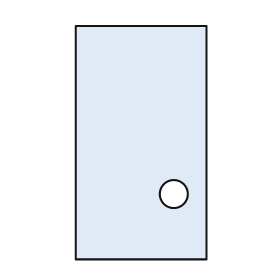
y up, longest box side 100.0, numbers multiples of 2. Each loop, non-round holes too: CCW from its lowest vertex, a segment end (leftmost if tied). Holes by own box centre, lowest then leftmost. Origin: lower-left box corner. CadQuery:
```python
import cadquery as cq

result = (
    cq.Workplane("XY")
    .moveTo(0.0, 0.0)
    .lineTo(56.0, 0.0)
    .lineTo(56.0, 100.0)
    .lineTo(0.0, 100.0)
    .close()
    .moveTo(42.0, 28.0)
    .circle(6.0)
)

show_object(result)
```